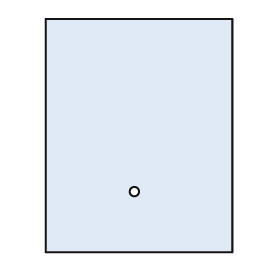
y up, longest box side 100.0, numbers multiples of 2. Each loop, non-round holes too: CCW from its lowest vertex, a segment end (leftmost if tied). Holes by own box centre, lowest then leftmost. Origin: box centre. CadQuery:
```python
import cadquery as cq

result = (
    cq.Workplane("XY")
    .moveTo(-40.0, -50.0)
    .lineTo(40.0, -50.0)
    .lineTo(40.0, 50.0)
    .lineTo(-40.0, 50.0)
    .close()
    .moveTo(-2.0, -24.0)
    .circle(2.0)
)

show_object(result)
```